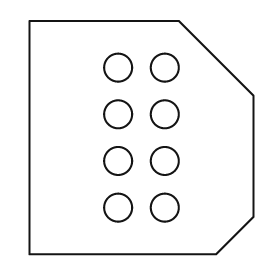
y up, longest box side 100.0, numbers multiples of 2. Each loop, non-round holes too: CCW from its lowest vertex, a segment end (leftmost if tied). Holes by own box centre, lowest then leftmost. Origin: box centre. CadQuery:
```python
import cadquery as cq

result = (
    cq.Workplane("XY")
    .moveTo(-48.0, -50.0)
    .lineTo(32.0, -50.0)
    .lineTo(48.0, -34.0)
    .lineTo(48.0, 18.0)
    .lineTo(16.0, 50.0)
    .lineTo(-48.0, 50.0)
    .close()
    .moveTo(-10.0, -30.0)
    .circle(6.0)
    .moveTo(10.0, -30.0)
    .circle(6.0)
    .moveTo(-10.0, -10.0)
    .circle(6.0)
    .moveTo(10.0, -10.0)
    .circle(6.0)
    .moveTo(-10.0, 10.0)
    .circle(6.0)
    .moveTo(10.0, 10.0)
    .circle(6.0)
    .moveTo(-10.0, 30.0)
    .circle(6.0)
    .moveTo(10.0, 30.0)
    .circle(6.0)
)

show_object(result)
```